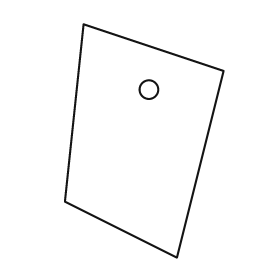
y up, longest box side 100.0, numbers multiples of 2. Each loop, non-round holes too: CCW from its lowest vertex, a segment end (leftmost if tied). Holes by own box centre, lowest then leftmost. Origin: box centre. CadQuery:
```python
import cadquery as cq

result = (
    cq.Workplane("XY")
    .moveTo(14.0, -50.0)
    .lineTo(34.0, 30.0)
    .lineTo(-26.0, 50.0)
    .lineTo(-34.0, -26.0)
    .close()
    .moveTo(2.0, 22.0)
    .circle(4.0)
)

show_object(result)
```